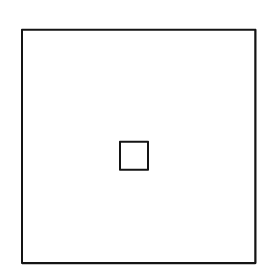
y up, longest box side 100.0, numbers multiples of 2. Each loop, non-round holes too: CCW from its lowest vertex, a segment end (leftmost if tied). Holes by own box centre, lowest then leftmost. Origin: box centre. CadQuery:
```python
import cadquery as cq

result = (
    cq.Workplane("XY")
    .moveTo(-50.0, -50.0)
    .lineTo(50.0, -50.0)
    .lineTo(50.0, 50.0)
    .lineTo(-50.0, 50.0)
    .close()
    .moveTo(-8.0, -10.0)
    .lineTo(4.0, -10.0)
    .lineTo(4.0, 2.0)
    .lineTo(-8.0, 2.0)
    .close()
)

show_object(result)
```